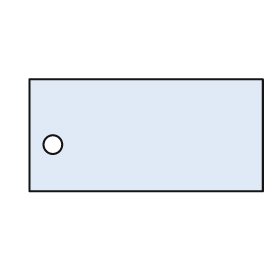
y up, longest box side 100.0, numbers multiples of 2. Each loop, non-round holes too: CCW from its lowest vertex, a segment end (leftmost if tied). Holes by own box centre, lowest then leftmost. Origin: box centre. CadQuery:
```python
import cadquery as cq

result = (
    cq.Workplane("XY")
    .moveTo(-50.0, -24.0)
    .lineTo(50.0, -24.0)
    .lineTo(50.0, 24.0)
    .lineTo(-50.0, 24.0)
    .close()
    .moveTo(-40.0, -4.0)
    .circle(4.0)
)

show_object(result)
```